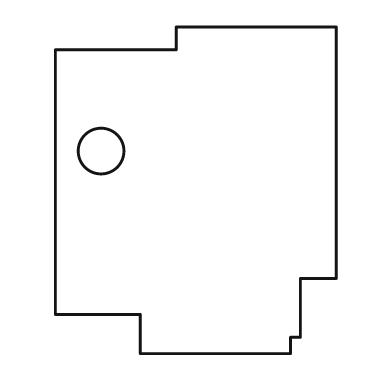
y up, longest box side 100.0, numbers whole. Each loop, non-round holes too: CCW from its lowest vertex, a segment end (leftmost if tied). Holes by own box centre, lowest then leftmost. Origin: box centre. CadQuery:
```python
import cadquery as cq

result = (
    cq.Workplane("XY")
    .moveTo(-17.0, -50.0)
    .lineTo(29.0, -50.0)
    .lineTo(29.0, -45.0)
    .lineTo(32.0, -45.0)
    .lineTo(32.0, -27.0)
    .lineTo(43.0, -27.0)
    .lineTo(43.0, 50.0)
    .lineTo(-6.0, 50.0)
    .lineTo(-6.0, 43.0)
    .lineTo(-43.0, 43.0)
    .lineTo(-43.0, -38.0)
    .lineTo(-17.0, -38.0)
    .close()
    .moveTo(-29.0, 12.0)
    .circle(7.0)
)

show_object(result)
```